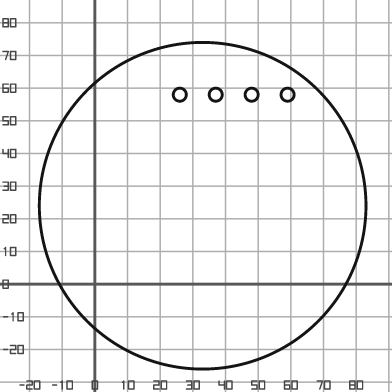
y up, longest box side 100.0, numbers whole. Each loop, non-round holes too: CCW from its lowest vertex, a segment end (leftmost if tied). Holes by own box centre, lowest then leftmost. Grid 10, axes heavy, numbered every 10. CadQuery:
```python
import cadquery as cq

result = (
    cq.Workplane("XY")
    .moveTo(33.0, 24.0)
    .circle(50.0)
    .moveTo(26.0, 58.0)
    .circle(2.0)
    .moveTo(37.0, 58.0)
    .circle(2.0)
    .moveTo(48.0, 58.0)
    .circle(2.0)
    .moveTo(59.0, 58.0)
    .circle(2.0)
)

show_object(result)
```